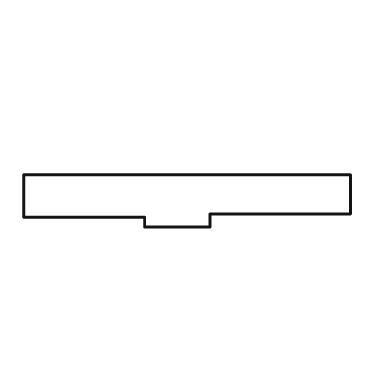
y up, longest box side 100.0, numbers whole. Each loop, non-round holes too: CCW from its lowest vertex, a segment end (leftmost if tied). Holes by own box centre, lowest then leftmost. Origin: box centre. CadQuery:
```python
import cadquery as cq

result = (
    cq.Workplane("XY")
    .moveTo(-13.0, -8.0)
    .lineTo(7.0, -8.0)
    .lineTo(7.0, -4.0)
    .lineTo(50.0, -4.0)
    .lineTo(50.0, 8.0)
    .lineTo(-50.0, 8.0)
    .lineTo(-50.0, -5.0)
    .lineTo(-13.0, -5.0)
    .close()
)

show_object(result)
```